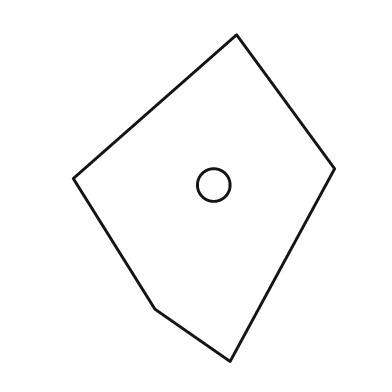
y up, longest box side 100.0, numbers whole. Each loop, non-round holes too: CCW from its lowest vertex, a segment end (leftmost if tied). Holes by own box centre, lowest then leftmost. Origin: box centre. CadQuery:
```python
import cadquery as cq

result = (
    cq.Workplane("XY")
    .moveTo(8.0, -50.0)
    .lineTo(40.0, 9.0)
    .lineTo(10.0, 50.0)
    .lineTo(-40.0, 6.0)
    .lineTo(-15.0, -34.0)
    .close()
    .moveTo(3.0, 4.0)
    .circle(5.0)
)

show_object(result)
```